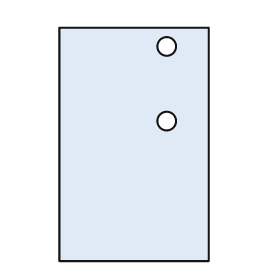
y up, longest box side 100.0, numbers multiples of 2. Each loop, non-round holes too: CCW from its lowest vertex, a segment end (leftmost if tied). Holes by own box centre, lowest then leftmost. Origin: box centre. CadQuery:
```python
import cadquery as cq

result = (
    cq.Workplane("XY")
    .moveTo(-32.0, -50.0)
    .lineTo(32.0, -50.0)
    .lineTo(32.0, 50.0)
    .lineTo(-32.0, 50.0)
    .close()
    .moveTo(14.0, 10.0)
    .circle(4.0)
    .moveTo(14.0, 42.0)
    .circle(4.0)
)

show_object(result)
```